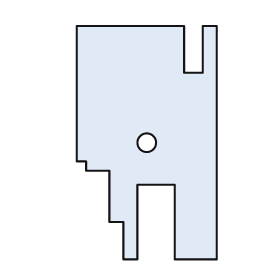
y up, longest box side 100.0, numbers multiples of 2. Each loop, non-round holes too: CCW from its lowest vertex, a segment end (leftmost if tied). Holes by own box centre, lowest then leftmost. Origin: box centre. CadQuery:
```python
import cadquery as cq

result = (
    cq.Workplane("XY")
    .moveTo(-10.0, -50.0)
    .lineTo(-4.0, -50.0)
    .lineTo(-4.0, -18.0)
    .lineTo(12.0, -18.0)
    .lineTo(12.0, -50.0)
    .lineTo(30.0, -50.0)
    .lineTo(30.0, 50.0)
    .lineTo(24.0, 50.0)
    .lineTo(24.0, 30.0)
    .lineTo(16.0, 30.0)
    .lineTo(16.0, 50.0)
    .lineTo(-30.0, 50.0)
    .lineTo(-30.0, -8.0)
    .lineTo(-26.0, -8.0)
    .lineTo(-26.0, -12.0)
    .lineTo(-16.0, -12.0)
    .lineTo(-16.0, -34.0)
    .lineTo(-10.0, -34.0)
    .close()
    .moveTo(0.0, 0.0)
    .circle(4.0)
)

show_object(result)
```